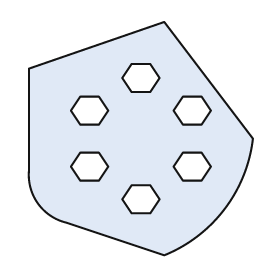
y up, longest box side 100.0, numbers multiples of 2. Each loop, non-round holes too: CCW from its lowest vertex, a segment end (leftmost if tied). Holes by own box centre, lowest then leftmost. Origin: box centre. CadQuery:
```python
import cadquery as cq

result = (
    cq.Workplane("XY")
    .moveTo(10.0, -50.0)
    .threePointArc((36.0, -30.0), (48.0, 0.0))
    .lineTo(10.0, 50.0)
    .lineTo(-48.0, 30.0)
    .lineTo(-48.0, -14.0)
    .threePointArc((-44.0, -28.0), (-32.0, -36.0))
    .close()
    .moveTo(-4.0, -32.0)
    .lineTo(4.0, -32.0)
    .lineTo(8.0, -26.0)
    .lineTo(4.0, -20.0)
    .lineTo(-4.0, -20.0)
    .lineTo(-8.0, -26.0)
    .close()
    .moveTo(-26.0, -18.0)
    .lineTo(-18.0, -18.0)
    .lineTo(-14.0, -12.0)
    .lineTo(-18.0, -6.0)
    .lineTo(-26.0, -6.0)
    .lineTo(-30.0, -12.0)
    .close()
    .moveTo(18.0, -18.0)
    .lineTo(26.0, -18.0)
    .lineTo(30.0, -12.0)
    .lineTo(26.0, -6.0)
    .lineTo(18.0, -6.0)
    .lineTo(14.0, -12.0)
    .close()
    .moveTo(-26.0, 6.0)
    .lineTo(-18.0, 6.0)
    .lineTo(-14.0, 12.0)
    .lineTo(-18.0, 18.0)
    .lineTo(-26.0, 18.0)
    .lineTo(-30.0, 12.0)
    .close()
    .moveTo(18.0, 6.0)
    .lineTo(26.0, 6.0)
    .lineTo(30.0, 12.0)
    .lineTo(26.0, 18.0)
    .lineTo(18.0, 18.0)
    .lineTo(14.0, 12.0)
    .close()
    .moveTo(-4.0, 20.0)
    .lineTo(4.0, 20.0)
    .lineTo(8.0, 26.0)
    .lineTo(4.0, 32.0)
    .lineTo(-4.0, 32.0)
    .lineTo(-8.0, 26.0)
    .close()
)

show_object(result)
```